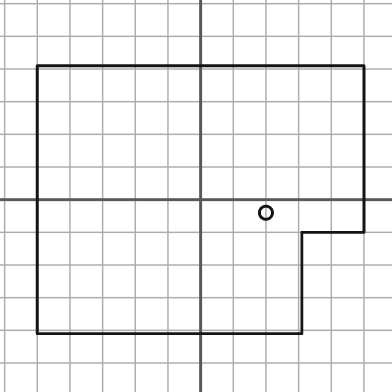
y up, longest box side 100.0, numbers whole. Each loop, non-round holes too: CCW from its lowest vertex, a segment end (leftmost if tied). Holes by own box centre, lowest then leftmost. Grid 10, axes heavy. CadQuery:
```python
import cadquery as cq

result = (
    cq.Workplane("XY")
    .moveTo(-50.0, -41.0)
    .lineTo(31.0, -41.0)
    .lineTo(31.0, -10.0)
    .lineTo(50.0, -10.0)
    .lineTo(50.0, 41.0)
    .lineTo(-50.0, 41.0)
    .close()
    .moveTo(20.0, -4.0)
    .circle(2.0)
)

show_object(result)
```